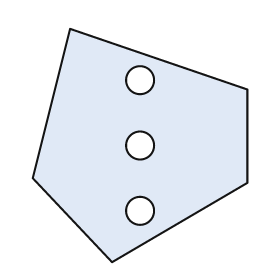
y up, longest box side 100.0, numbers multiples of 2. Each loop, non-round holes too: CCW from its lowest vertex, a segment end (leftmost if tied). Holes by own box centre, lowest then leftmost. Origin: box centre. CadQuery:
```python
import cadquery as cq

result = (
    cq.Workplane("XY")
    .moveTo(-12.0, -50.0)
    .lineTo(46.0, -16.0)
    .lineTo(46.0, 24.0)
    .lineTo(-30.0, 50.0)
    .lineTo(-46.0, -14.0)
    .close()
    .moveTo(0.0, -28.0)
    .circle(6.0)
    .moveTo(0.0, 0.0)
    .circle(6.0)
    .moveTo(0.0, 28.0)
    .circle(6.0)
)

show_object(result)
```